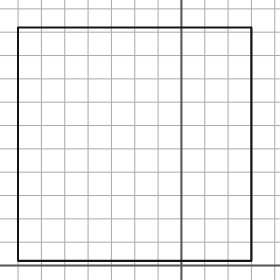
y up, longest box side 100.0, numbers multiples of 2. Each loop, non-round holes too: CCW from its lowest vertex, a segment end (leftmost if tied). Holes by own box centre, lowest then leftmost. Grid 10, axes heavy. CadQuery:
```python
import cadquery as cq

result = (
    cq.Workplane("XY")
    .moveTo(-70.0, 2.0)
    .lineTo(30.0, 2.0)
    .lineTo(30.0, 102.0)
    .lineTo(-70.0, 102.0)
    .close()
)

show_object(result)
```